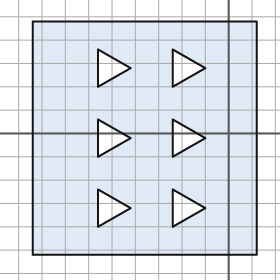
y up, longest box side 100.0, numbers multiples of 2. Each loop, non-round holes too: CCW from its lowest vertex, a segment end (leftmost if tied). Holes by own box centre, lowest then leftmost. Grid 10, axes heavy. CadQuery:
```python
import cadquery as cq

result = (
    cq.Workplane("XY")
    .moveTo(-84.0, -52.0)
    .lineTo(12.0, -52.0)
    .lineTo(12.0, 48.0)
    .lineTo(-84.0, 48.0)
    .close()
    .moveTo(-56.0, -40.0)
    .lineTo(-42.0, -32.0)
    .lineTo(-56.0, -24.0)
    .close()
    .moveTo(-24.0, -40.0)
    .lineTo(-10.0, -32.0)
    .lineTo(-24.0, -24.0)
    .close()
    .moveTo(-56.0, -10.0)
    .lineTo(-42.0, -2.0)
    .lineTo(-56.0, 6.0)
    .close()
    .moveTo(-24.0, -10.0)
    .lineTo(-10.0, -2.0)
    .lineTo(-24.0, 6.0)
    .close()
    .moveTo(-56.0, 20.0)
    .lineTo(-42.0, 28.0)
    .lineTo(-56.0, 36.0)
    .close()
    .moveTo(-24.0, 20.0)
    .lineTo(-10.0, 28.0)
    .lineTo(-24.0, 36.0)
    .close()
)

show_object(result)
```